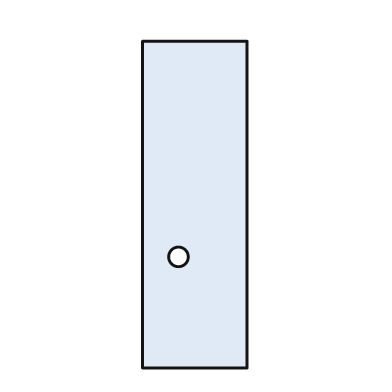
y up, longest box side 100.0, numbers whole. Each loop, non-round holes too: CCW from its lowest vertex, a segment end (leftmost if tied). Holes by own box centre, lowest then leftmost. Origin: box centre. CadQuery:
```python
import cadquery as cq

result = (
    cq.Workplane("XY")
    .moveTo(-16.0, -50.0)
    .lineTo(16.0, -50.0)
    .lineTo(16.0, 50.0)
    .lineTo(-16.0, 50.0)
    .close()
    .moveTo(-5.0, -16.0)
    .circle(3.0)
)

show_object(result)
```